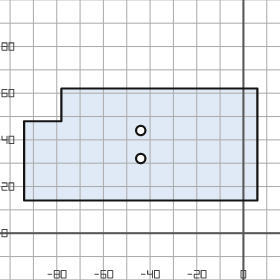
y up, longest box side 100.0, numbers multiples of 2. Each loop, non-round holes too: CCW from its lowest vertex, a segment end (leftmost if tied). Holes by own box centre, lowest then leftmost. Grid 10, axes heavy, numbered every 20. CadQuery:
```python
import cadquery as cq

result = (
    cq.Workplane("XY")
    .moveTo(-94.0, 14.0)
    .lineTo(6.0, 14.0)
    .lineTo(6.0, 62.0)
    .lineTo(-78.0, 62.0)
    .lineTo(-78.0, 48.0)
    .lineTo(-94.0, 48.0)
    .close()
    .moveTo(-44.0, 32.0)
    .circle(2.0)
    .moveTo(-44.0, 44.0)
    .circle(2.0)
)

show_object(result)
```